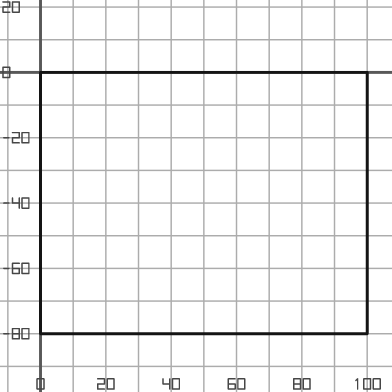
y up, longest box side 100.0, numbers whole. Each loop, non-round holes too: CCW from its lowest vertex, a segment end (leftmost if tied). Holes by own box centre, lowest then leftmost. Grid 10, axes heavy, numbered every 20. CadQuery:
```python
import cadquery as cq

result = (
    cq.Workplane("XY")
    .moveTo(0.0, -80.0)
    .lineTo(100.0, -80.0)
    .lineTo(100.0, 0.0)
    .lineTo(0.0, 0.0)
    .close()
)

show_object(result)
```